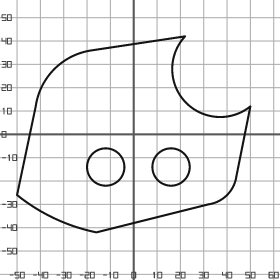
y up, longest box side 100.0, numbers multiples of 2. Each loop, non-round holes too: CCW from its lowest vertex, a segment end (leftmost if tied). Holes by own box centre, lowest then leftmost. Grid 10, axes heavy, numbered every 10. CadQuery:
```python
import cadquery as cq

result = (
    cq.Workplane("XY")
    .moveTo(-16.0, -42.0)
    .lineTo(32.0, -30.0)
    .threePointArc((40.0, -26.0), (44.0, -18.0))
    .lineTo(50.0, 12.0)
    .threePointArc((22.0, 14.0), (22.0, 42.0))
    .lineTo(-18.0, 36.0)
    .threePointArc((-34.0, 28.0), (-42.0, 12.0))
    .lineTo(-50.0, -26.0)
    .threePointArc((-34.0, -36.0), (-16.0, -42.0))
    .close()
    .moveTo(-12.0, -14.0)
    .circle(8.0)
    .moveTo(16.0, -14.0)
    .circle(8.0)
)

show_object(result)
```